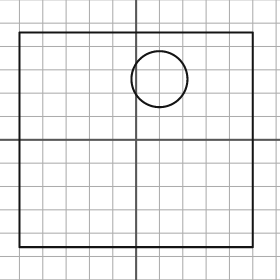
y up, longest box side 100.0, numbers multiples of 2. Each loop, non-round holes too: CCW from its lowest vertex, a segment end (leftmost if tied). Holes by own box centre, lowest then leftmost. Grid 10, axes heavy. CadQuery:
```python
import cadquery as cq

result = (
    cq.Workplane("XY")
    .moveTo(-50.0, -46.0)
    .lineTo(50.0, -46.0)
    .lineTo(50.0, 46.0)
    .lineTo(-50.0, 46.0)
    .close()
    .moveTo(10.0, 26.0)
    .circle(12.0)
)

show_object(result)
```